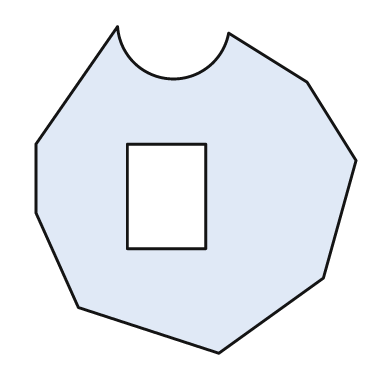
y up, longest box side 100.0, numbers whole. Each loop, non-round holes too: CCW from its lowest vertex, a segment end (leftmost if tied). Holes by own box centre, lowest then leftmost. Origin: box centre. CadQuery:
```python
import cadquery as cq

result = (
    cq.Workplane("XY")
    .moveTo(7.0, -50.0)
    .lineTo(39.0, -27.0)
    .lineTo(49.0, 9.0)
    .lineTo(34.0, 33.0)
    .lineTo(10.0, 48.0)
    .threePointArc((-8.0, 34.0), (-24.0, 50.0))
    .lineTo(-49.0, 14.0)
    .lineTo(-49.0, -7.0)
    .lineTo(-36.0, -36.0)
    .close()
    .moveTo(-21.0, -18.0)
    .lineTo(3.0, -18.0)
    .lineTo(3.0, 14.0)
    .lineTo(-21.0, 14.0)
    .close()
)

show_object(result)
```